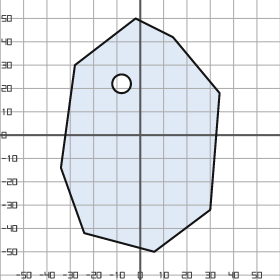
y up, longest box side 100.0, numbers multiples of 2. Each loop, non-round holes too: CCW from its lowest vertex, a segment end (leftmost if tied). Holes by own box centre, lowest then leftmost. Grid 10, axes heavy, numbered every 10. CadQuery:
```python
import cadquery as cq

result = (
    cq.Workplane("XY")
    .moveTo(6.0, -50.0)
    .lineTo(30.0, -32.0)
    .lineTo(34.0, 18.0)
    .lineTo(14.0, 42.0)
    .lineTo(-2.0, 50.0)
    .lineTo(-28.0, 30.0)
    .lineTo(-34.0, -14.0)
    .lineTo(-24.0, -42.0)
    .close()
    .moveTo(-8.0, 22.0)
    .circle(4.0)
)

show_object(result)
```